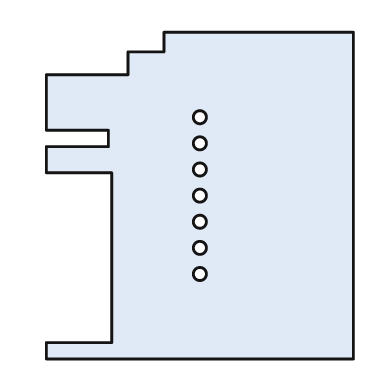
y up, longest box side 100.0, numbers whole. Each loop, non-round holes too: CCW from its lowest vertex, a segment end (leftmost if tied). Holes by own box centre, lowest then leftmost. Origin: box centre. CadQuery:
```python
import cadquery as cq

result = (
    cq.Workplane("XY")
    .moveTo(-47.0, -50.0)
    .lineTo(47.0, -50.0)
    .lineTo(47.0, 50.0)
    .lineTo(-11.0, 50.0)
    .lineTo(-11.0, 44.0)
    .lineTo(-22.0, 44.0)
    .lineTo(-22.0, 37.0)
    .lineTo(-47.0, 37.0)
    .lineTo(-47.0, 20.0)
    .lineTo(-28.0, 20.0)
    .lineTo(-28.0, 15.0)
    .lineTo(-47.0, 15.0)
    .lineTo(-47.0, 7.0)
    .lineTo(-27.0, 7.0)
    .lineTo(-27.0, -45.0)
    .lineTo(-47.0, -45.0)
    .close()
    .moveTo(0.0, -24.0)
    .circle(2.0)
    .moveTo(0.0, -16.0)
    .circle(2.0)
    .moveTo(0.0, -8.0)
    .circle(2.0)
    .moveTo(0.0, 0.0)
    .circle(2.0)
    .moveTo(0.0, 8.0)
    .circle(2.0)
    .moveTo(0.0, 16.0)
    .circle(2.0)
    .moveTo(0.0, 24.0)
    .circle(2.0)
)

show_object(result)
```